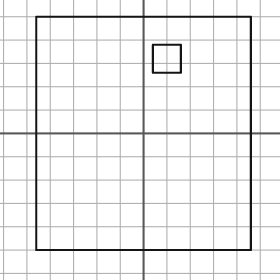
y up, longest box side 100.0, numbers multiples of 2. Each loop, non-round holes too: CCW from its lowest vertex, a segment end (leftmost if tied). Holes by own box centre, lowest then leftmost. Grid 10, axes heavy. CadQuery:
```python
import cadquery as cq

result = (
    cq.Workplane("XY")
    .moveTo(-46.0, -50.0)
    .lineTo(46.0, -50.0)
    .lineTo(46.0, 50.0)
    .lineTo(-46.0, 50.0)
    .close()
    .moveTo(4.0, 26.0)
    .lineTo(16.0, 26.0)
    .lineTo(16.0, 38.0)
    .lineTo(4.0, 38.0)
    .close()
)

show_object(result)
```